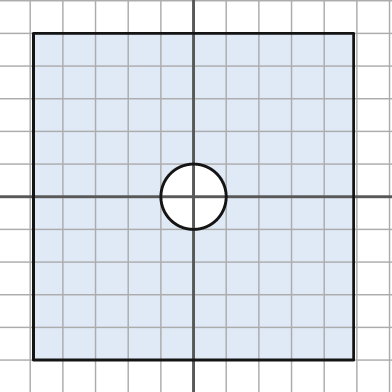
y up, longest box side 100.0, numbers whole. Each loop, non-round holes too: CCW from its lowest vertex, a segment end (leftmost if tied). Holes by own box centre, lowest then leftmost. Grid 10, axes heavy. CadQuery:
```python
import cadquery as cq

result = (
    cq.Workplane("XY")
    .moveTo(-49.0, -50.0)
    .lineTo(49.0, -50.0)
    .lineTo(49.0, 50.0)
    .lineTo(-49.0, 50.0)
    .close()
    .moveTo(0.0, 0.0)
    .circle(10.0)
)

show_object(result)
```